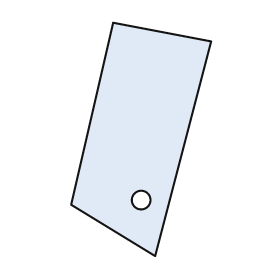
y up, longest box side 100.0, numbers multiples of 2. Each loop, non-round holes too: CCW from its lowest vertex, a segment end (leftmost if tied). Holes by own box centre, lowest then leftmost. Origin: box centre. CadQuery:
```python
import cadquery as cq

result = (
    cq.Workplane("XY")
    .moveTo(6.0, -50.0)
    .lineTo(30.0, 42.0)
    .lineTo(-12.0, 50.0)
    .lineTo(-30.0, -28.0)
    .close()
    .moveTo(0.0, -26.0)
    .circle(4.0)
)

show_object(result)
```